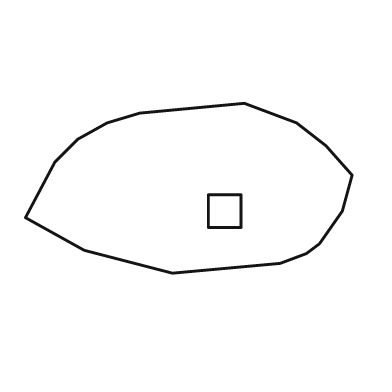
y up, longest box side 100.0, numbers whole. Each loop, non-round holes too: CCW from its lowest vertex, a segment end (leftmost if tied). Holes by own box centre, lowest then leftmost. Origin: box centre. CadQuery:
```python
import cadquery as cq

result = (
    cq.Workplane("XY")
    .moveTo(-5.0, -26.0)
    .lineTo(28.0, -23.0)
    .lineTo(36.0, -20.0)
    .lineTo(40.0, -17.0)
    .lineTo(47.0, -7.0)
    .lineTo(50.0, 4.0)
    .lineTo(42.0, 13.0)
    .lineTo(33.0, 20.0)
    .lineTo(17.0, 26.0)
    .lineTo(-15.0, 23.0)
    .lineTo(-25.0, 20.0)
    .lineTo(-34.0, 15.0)
    .lineTo(-41.0, 8.0)
    .lineTo(-50.0, -9.0)
    .lineTo(-32.0, -19.0)
    .close()
    .moveTo(6.0, -12.0)
    .lineTo(16.0, -12.0)
    .lineTo(16.0, -2.0)
    .lineTo(6.0, -2.0)
    .close()
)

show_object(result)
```